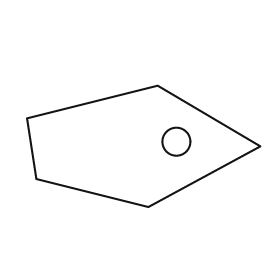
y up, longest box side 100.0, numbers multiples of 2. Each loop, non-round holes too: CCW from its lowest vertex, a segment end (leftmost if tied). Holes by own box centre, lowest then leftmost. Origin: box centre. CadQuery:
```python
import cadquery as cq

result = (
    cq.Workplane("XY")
    .moveTo(2.0, -26.0)
    .lineTo(50.0, 0.0)
    .lineTo(6.0, 26.0)
    .lineTo(-50.0, 12.0)
    .lineTo(-46.0, -14.0)
    .close()
    .moveTo(14.0, 2.0)
    .circle(6.0)
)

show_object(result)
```